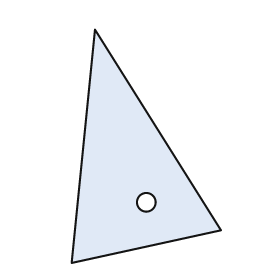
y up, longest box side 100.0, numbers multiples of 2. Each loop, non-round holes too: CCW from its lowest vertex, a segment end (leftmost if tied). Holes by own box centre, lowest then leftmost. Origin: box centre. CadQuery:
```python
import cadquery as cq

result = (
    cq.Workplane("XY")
    .moveTo(-32.0, -50.0)
    .lineTo(32.0, -36.0)
    .lineTo(-22.0, 50.0)
    .close()
    .moveTo(0.0, -24.0)
    .circle(4.0)
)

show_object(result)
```